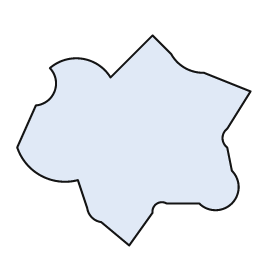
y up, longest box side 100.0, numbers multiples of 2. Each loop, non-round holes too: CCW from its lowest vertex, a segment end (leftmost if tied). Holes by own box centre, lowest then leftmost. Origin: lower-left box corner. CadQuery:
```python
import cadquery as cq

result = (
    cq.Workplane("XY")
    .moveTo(48.0, 0.0)
    .lineTo(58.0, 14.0)
    .threePointArc((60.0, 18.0), (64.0, 18.0))
    .lineTo(78.0, 18.0)
    .threePointArc((92.0, 18.0), (92.0, 32.0))
    .lineTo(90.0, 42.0)
    .threePointArc((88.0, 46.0), (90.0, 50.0))
    .lineTo(100.0, 66.0)
    .lineTo(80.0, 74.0)
    .threePointArc((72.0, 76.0), (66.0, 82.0))
    .lineTo(58.0, 90.0)
    .lineTo(40.0, 72.0)
    .threePointArc((28.0, 80.0), (14.0, 76.0))
    .threePointArc((16.0, 66.0), (8.0, 60.0))
    .lineTo(0.0, 42.0)
    .threePointArc((10.0, 30.0), (26.0, 28.0))
    .lineTo(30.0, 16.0)
    .threePointArc((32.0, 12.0), (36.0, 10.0))
    .close()
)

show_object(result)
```